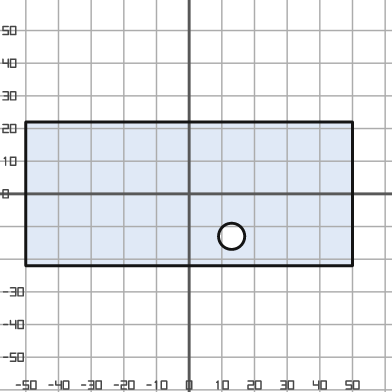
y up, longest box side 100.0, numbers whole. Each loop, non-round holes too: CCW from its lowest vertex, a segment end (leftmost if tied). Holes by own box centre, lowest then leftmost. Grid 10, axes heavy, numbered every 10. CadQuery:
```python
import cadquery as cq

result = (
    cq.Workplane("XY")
    .moveTo(-50.0, -22.0)
    .lineTo(50.0, -22.0)
    .lineTo(50.0, 22.0)
    .lineTo(-50.0, 22.0)
    .close()
    .moveTo(13.0, -13.0)
    .circle(4.0)
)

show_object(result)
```